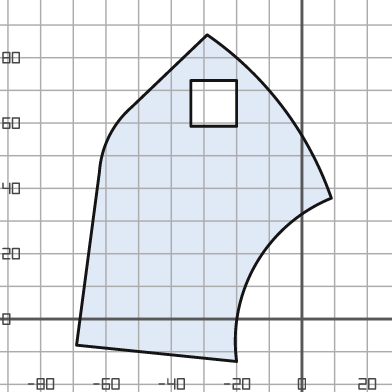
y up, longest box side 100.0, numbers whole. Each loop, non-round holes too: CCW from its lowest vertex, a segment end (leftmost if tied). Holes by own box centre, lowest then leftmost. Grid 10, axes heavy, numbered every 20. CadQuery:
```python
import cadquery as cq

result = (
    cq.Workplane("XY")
    .moveTo(-20.0, -13.0)
    .threePointArc((-14.0, 17.0), (9.0, 37.0))
    .threePointArc((-6.0, 65.0), (-29.0, 87.0))
    .lineTo(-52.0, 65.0)
    .threePointArc((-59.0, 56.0), (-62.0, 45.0))
    .lineTo(-69.0, -8.0)
    .close()
    .moveTo(-34.0, 59.0)
    .lineTo(-20.0, 59.0)
    .lineTo(-20.0, 73.0)
    .lineTo(-34.0, 73.0)
    .close()
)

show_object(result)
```